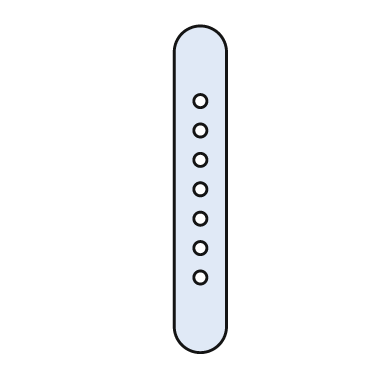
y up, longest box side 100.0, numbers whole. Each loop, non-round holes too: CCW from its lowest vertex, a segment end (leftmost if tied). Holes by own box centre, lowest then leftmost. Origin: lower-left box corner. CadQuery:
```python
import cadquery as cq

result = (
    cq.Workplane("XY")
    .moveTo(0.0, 8.0)
    .threePointArc((8.0, 0.0), (16.0, 8.0))
    .lineTo(16.0, 92.0)
    .threePointArc((8.0, 100.0), (0.0, 92.0))
    .close()
    .moveTo(8.0, 23.0)
    .circle(2.0)
    .moveTo(8.0, 32.0)
    .circle(2.0)
    .moveTo(8.0, 41.0)
    .circle(2.0)
    .moveTo(8.0, 50.0)
    .circle(2.0)
    .moveTo(8.0, 59.0)
    .circle(2.0)
    .moveTo(8.0, 68.0)
    .circle(2.0)
    .moveTo(8.0, 77.0)
    .circle(2.0)
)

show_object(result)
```